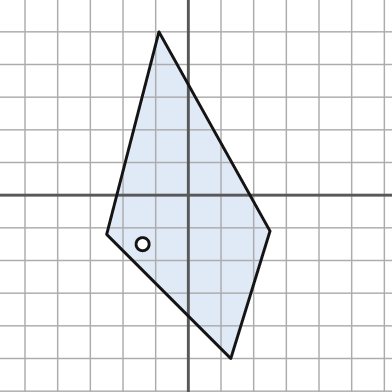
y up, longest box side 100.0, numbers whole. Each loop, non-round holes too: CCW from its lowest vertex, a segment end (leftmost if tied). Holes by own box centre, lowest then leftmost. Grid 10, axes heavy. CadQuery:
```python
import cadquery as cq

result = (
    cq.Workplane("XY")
    .moveTo(13.0, -50.0)
    .lineTo(25.0, -11.0)
    .lineTo(-9.0, 50.0)
    .lineTo(-25.0, -12.0)
    .close()
    .moveTo(-14.0, -15.0)
    .circle(2.0)
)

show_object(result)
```